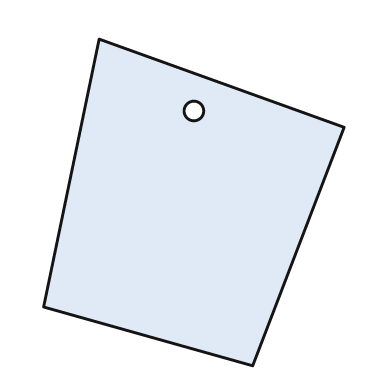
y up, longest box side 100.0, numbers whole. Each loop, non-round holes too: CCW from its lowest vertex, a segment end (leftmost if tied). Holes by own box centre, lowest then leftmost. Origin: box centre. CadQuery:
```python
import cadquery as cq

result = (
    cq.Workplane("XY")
    .moveTo(18.0, -50.0)
    .lineTo(46.0, 23.0)
    .lineTo(-29.0, 50.0)
    .lineTo(-46.0, -32.0)
    .close()
    .moveTo(0.0, 28.0)
    .circle(3.0)
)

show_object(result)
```